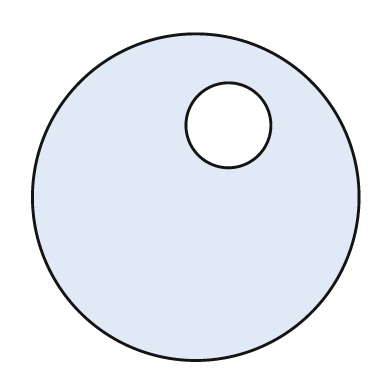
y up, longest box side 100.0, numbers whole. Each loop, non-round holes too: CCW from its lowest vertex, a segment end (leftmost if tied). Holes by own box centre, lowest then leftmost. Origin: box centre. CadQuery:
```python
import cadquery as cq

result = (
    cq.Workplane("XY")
    .moveTo(0.0, 0.0)
    .circle(50.0)
    .moveTo(10.0, 22.0)
    .circle(13.0)
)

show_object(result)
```